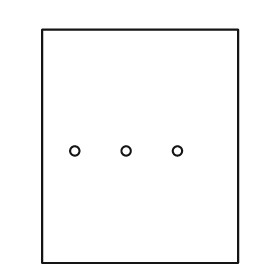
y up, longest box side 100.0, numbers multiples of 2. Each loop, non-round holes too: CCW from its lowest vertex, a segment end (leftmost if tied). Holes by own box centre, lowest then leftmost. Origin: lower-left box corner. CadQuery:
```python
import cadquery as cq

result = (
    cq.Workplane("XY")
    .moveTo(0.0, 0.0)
    .lineTo(84.0, 0.0)
    .lineTo(84.0, 100.0)
    .lineTo(0.0, 100.0)
    .close()
    .moveTo(14.0, 48.0)
    .circle(2.0)
    .moveTo(36.0, 48.0)
    .circle(2.0)
    .moveTo(58.0, 48.0)
    .circle(2.0)
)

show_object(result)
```